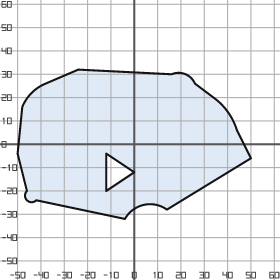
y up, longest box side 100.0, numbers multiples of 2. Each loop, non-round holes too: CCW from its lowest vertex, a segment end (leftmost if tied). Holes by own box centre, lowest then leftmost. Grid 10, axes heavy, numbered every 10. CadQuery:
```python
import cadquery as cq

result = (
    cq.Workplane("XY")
    .moveTo(-4.0, -32.0)
    .threePointArc((4.0, -26.0), (14.0, -28.0))
    .lineTo(50.0, -6.0)
    .lineTo(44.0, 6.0)
    .threePointArc((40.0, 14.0), (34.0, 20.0))
    .lineTo(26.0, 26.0)
    .threePointArc((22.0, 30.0), (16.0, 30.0))
    .lineTo(-24.0, 32.0)
    .lineTo(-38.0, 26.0)
    .threePointArc((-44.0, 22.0), (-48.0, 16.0))
    .lineTo(-50.0, -4.0)
    .lineTo(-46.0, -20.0)
    .threePointArc((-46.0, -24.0), (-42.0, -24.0))
    .close()
    .moveTo(-12.0, -20.0)
    .lineTo(0.0, -12.0)
    .lineTo(-12.0, -4.0)
    .close()
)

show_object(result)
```